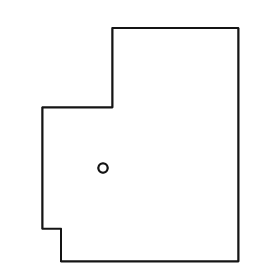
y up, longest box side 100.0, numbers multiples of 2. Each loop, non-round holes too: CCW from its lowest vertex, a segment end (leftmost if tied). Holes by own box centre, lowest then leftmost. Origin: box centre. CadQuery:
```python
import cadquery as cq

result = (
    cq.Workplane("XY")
    .moveTo(-34.0, -50.0)
    .lineTo(42.0, -50.0)
    .lineTo(42.0, 50.0)
    .lineTo(-12.0, 50.0)
    .lineTo(-12.0, 16.0)
    .lineTo(-42.0, 16.0)
    .lineTo(-42.0, -36.0)
    .lineTo(-34.0, -36.0)
    .close()
    .moveTo(-16.0, -10.0)
    .circle(2.0)
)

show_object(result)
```